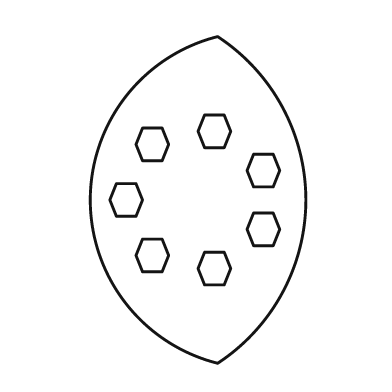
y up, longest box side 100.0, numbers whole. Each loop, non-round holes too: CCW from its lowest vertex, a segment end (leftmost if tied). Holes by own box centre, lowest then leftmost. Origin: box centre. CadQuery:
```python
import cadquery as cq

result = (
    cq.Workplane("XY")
    .moveTo(6.0, -50.0)
    .threePointArc((33.0, 0.0), (6.0, 50.0))
    .threePointArc((-33.0, 0.0), (6.0, -50.0))
    .close()
    .moveTo(2.0, -26.0)
    .lineTo(8.0, -26.0)
    .lineTo(10.0, -21.0)
    .lineTo(8.0, -16.0)
    .lineTo(2.0, -16.0)
    .lineTo(0.0, -21.0)
    .close()
    .moveTo(-17.0, -22.0)
    .lineTo(-11.0, -22.0)
    .lineTo(-9.0, -17.0)
    .lineTo(-11.0, -12.0)
    .lineTo(-17.0, -12.0)
    .lineTo(-19.0, -17.0)
    .close()
    .moveTo(17.0, -14.0)
    .lineTo(23.0, -14.0)
    .lineTo(25.0, -9.0)
    .lineTo(23.0, -4.0)
    .lineTo(17.0, -4.0)
    .lineTo(15.0, -9.0)
    .close()
    .moveTo(-25.0, -5.0)
    .lineTo(-19.0, -5.0)
    .lineTo(-17.0, 0.0)
    .lineTo(-19.0, 5.0)
    .lineTo(-25.0, 5.0)
    .lineTo(-27.0, 0.0)
    .close()
    .moveTo(17.0, 4.0)
    .lineTo(23.0, 4.0)
    .lineTo(25.0, 9.0)
    .lineTo(23.0, 14.0)
    .lineTo(17.0, 14.0)
    .lineTo(15.0, 9.0)
    .close()
    .moveTo(-17.0, 12.0)
    .lineTo(-11.0, 12.0)
    .lineTo(-9.0, 17.0)
    .lineTo(-11.0, 22.0)
    .lineTo(-17.0, 22.0)
    .lineTo(-19.0, 17.0)
    .close()
    .moveTo(2.0, 16.0)
    .lineTo(8.0, 16.0)
    .lineTo(10.0, 21.0)
    .lineTo(8.0, 26.0)
    .lineTo(2.0, 26.0)
    .lineTo(0.0, 21.0)
    .close()
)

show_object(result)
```